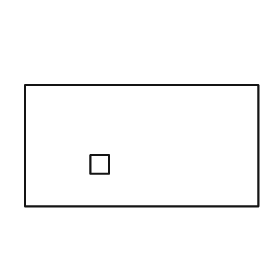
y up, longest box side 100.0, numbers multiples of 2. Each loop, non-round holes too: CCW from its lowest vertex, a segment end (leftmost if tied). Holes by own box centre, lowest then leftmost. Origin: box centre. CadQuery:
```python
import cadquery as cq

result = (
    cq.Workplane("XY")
    .moveTo(-50.0, -26.0)
    .lineTo(50.0, -26.0)
    .lineTo(50.0, 26.0)
    .lineTo(-50.0, 26.0)
    .close()
    .moveTo(-22.0, -12.0)
    .lineTo(-14.0, -12.0)
    .lineTo(-14.0, -4.0)
    .lineTo(-22.0, -4.0)
    .close()
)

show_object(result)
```